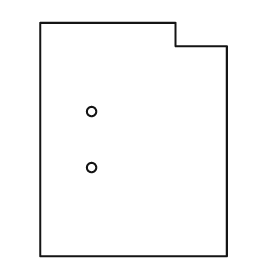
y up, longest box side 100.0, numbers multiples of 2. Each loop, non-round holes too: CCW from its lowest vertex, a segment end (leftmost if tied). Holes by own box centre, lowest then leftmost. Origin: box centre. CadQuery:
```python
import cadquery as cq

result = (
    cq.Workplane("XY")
    .moveTo(-40.0, -50.0)
    .lineTo(40.0, -50.0)
    .lineTo(40.0, 40.0)
    .lineTo(18.0, 40.0)
    .lineTo(18.0, 50.0)
    .lineTo(-40.0, 50.0)
    .close()
    .moveTo(-18.0, -12.0)
    .circle(2.0)
    .moveTo(-18.0, 12.0)
    .circle(2.0)
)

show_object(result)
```